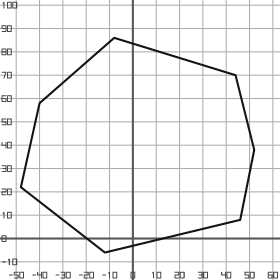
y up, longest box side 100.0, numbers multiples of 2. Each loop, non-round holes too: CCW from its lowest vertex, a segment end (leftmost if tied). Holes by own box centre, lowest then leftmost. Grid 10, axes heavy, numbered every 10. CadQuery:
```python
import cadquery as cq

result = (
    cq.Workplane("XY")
    .moveTo(-12.0, -6.0)
    .lineTo(46.0, 8.0)
    .lineTo(52.0, 38.0)
    .lineTo(44.0, 70.0)
    .lineTo(-8.0, 86.0)
    .lineTo(-40.0, 58.0)
    .lineTo(-48.0, 22.0)
    .close()
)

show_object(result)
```